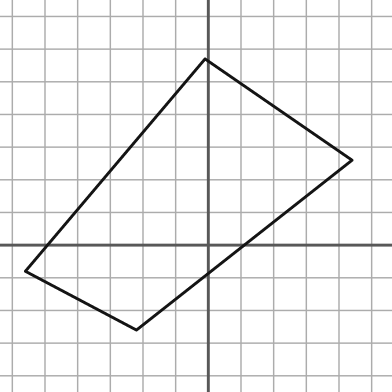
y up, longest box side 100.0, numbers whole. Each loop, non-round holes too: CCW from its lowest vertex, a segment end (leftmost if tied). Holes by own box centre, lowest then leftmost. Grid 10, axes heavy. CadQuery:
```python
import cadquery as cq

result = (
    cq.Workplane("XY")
    .moveTo(-22.0, -26.0)
    .lineTo(44.0, 26.0)
    .lineTo(-1.0, 57.0)
    .lineTo(-56.0, -8.0)
    .close()
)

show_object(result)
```